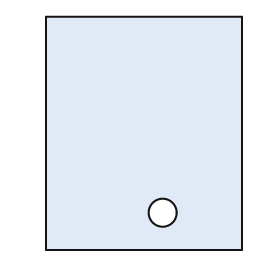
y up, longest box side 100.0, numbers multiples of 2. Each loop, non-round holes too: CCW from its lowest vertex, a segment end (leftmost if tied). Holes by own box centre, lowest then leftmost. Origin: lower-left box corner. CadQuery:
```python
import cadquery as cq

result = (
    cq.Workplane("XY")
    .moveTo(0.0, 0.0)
    .lineTo(84.0, 0.0)
    .lineTo(84.0, 100.0)
    .lineTo(0.0, 100.0)
    .close()
    .moveTo(50.0, 16.0)
    .circle(6.0)
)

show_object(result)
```